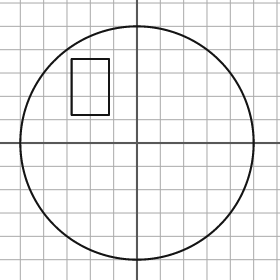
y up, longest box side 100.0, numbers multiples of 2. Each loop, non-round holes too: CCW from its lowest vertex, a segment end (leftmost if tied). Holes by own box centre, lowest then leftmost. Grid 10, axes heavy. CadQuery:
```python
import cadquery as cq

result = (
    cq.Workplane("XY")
    .moveTo(0.0, 0.0)
    .circle(50.0)
    .moveTo(-28.0, 12.0)
    .lineTo(-12.0, 12.0)
    .lineTo(-12.0, 36.0)
    .lineTo(-28.0, 36.0)
    .close()
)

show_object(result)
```